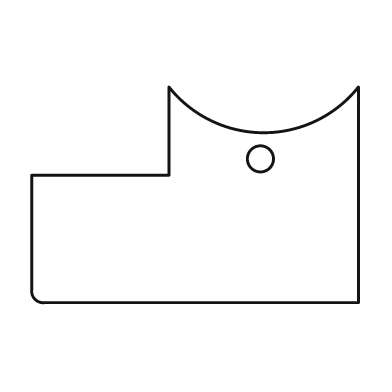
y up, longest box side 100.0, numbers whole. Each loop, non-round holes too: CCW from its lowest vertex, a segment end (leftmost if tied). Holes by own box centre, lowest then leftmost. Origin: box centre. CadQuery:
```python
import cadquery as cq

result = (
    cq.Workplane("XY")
    .moveTo(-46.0, -33.0)
    .lineTo(50.0, -33.0)
    .lineTo(50.0, 33.0)
    .threePointArc((21.0, 19.0), (-8.0, 33.0))
    .lineTo(-8.0, 6.0)
    .lineTo(-50.0, 6.0)
    .lineTo(-50.0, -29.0)
    .threePointArc((-49.0, -32.0), (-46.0, -33.0))
    .close()
    .moveTo(20.0, 11.0)
    .circle(4.0)
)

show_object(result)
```